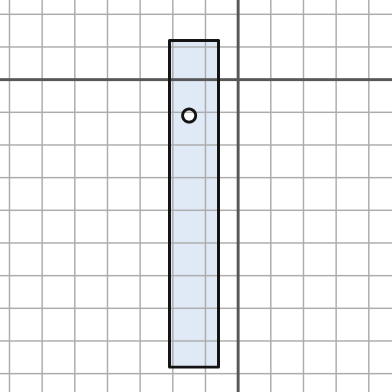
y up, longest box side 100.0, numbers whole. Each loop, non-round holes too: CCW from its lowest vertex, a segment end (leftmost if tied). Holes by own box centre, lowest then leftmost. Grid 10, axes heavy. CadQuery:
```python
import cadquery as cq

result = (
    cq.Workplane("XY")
    .moveTo(-21.0, -88.0)
    .lineTo(-6.0, -88.0)
    .lineTo(-6.0, 12.0)
    .lineTo(-21.0, 12.0)
    .close()
    .moveTo(-15.0, -11.0)
    .circle(2.0)
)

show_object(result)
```